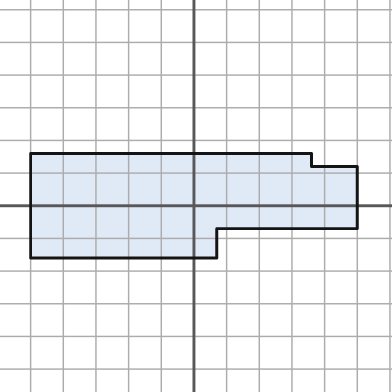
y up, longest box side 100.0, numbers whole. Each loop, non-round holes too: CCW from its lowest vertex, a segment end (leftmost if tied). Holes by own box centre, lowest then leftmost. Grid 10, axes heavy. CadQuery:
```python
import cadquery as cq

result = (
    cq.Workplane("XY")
    .moveTo(-50.0, -16.0)
    .lineTo(7.0, -16.0)
    .lineTo(7.0, -7.0)
    .lineTo(50.0, -7.0)
    .lineTo(50.0, 12.0)
    .lineTo(36.0, 12.0)
    .lineTo(36.0, 16.0)
    .lineTo(-50.0, 16.0)
    .close()
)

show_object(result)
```